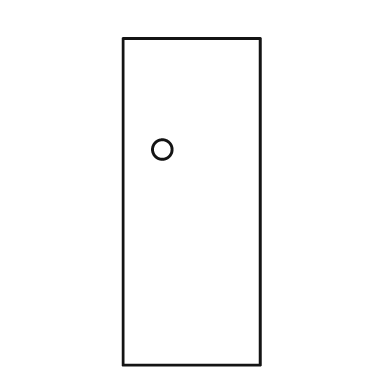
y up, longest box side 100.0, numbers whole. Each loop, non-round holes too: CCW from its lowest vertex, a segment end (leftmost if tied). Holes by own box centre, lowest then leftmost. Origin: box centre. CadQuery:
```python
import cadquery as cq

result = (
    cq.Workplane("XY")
    .moveTo(-21.0, -50.0)
    .lineTo(21.0, -50.0)
    .lineTo(21.0, 50.0)
    .lineTo(-21.0, 50.0)
    .close()
    .moveTo(-9.0, 16.0)
    .circle(3.0)
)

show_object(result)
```